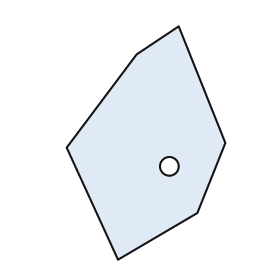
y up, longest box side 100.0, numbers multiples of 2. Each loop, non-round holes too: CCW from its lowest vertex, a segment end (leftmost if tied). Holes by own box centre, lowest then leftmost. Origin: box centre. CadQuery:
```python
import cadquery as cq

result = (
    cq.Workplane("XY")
    .moveTo(-12.0, -50.0)
    .lineTo(22.0, -30.0)
    .lineTo(34.0, 0.0)
    .lineTo(14.0, 50.0)
    .lineTo(-4.0, 38.0)
    .lineTo(-34.0, -2.0)
    .close()
    .moveTo(10.0, -10.0)
    .circle(4.0)
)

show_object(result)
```